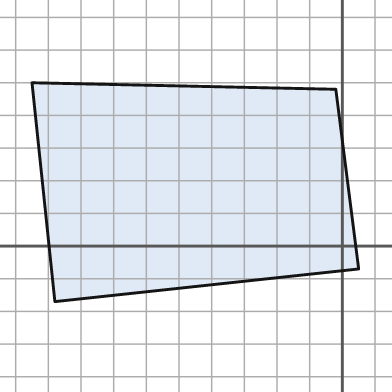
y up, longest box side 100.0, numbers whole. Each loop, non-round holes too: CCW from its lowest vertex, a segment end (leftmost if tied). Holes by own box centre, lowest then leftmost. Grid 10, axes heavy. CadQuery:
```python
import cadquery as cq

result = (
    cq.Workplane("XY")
    .moveTo(-88.0, -17.0)
    .lineTo(5.0, -7.0)
    .lineTo(-2.0, 48.0)
    .lineTo(-95.0, 50.0)
    .close()
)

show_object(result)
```